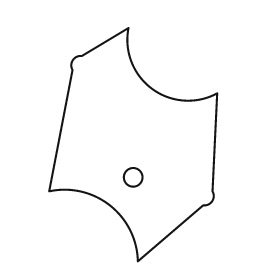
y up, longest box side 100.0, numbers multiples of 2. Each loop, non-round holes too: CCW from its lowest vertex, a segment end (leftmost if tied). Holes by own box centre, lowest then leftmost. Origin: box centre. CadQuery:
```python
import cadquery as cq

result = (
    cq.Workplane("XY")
    .moveTo(2.0, -50.0)
    .lineTo(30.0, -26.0)
    .threePointArc((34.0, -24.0), (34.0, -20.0))
    .lineTo(36.0, 22.0)
    .threePointArc((8.0, 24.0), (-2.0, 50.0))
    .lineTo(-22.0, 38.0)
    .threePointArc((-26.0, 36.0), (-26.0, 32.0))
    .lineTo(-36.0, -20.0)
    .threePointArc((-10.0, -26.0), (2.0, -50.0))
    .close()
    .moveTo(0.0, -14.0)
    .circle(4.0)
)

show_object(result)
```